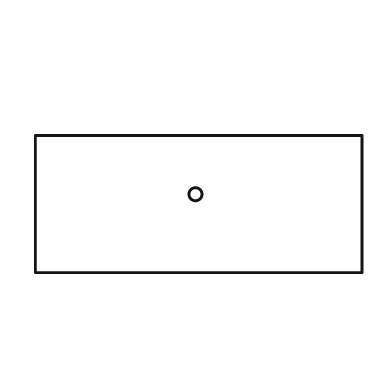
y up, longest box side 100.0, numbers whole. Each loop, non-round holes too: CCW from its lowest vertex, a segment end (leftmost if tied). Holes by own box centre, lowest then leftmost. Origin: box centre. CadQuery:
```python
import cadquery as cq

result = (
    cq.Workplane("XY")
    .moveTo(-50.0, -21.0)
    .lineTo(50.0, -21.0)
    .lineTo(50.0, 21.0)
    .lineTo(-50.0, 21.0)
    .close()
    .moveTo(-1.0, 3.0)
    .circle(2.0)
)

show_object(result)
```